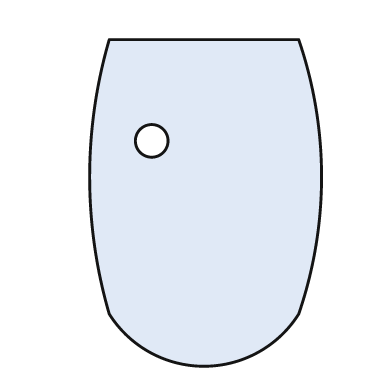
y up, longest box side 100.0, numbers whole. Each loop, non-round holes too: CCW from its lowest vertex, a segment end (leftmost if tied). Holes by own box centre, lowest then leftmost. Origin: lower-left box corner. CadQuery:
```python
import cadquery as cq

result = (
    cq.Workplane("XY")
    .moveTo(6.0, 16.0)
    .threePointArc((35.0, 0.0), (64.0, 16.0))
    .threePointArc((71.0, 58.0), (64.0, 100.0))
    .lineTo(6.0, 100.0)
    .threePointArc((0.0, 58.0), (6.0, 16.0))
    .close()
    .moveTo(19.0, 69.0)
    .circle(5.0)
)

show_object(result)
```